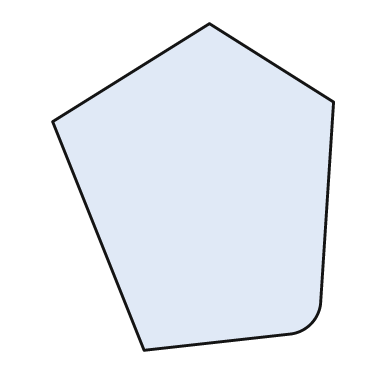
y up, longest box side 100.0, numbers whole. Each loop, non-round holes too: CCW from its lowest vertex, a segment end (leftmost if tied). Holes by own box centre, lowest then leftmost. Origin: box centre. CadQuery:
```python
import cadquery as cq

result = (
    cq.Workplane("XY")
    .moveTo(-15.0, -50.0)
    .lineTo(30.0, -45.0)
    .threePointArc((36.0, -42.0), (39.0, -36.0))
    .lineTo(43.0, 26.0)
    .lineTo(5.0, 50.0)
    .lineTo(-43.0, 20.0)
    .close()
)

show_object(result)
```